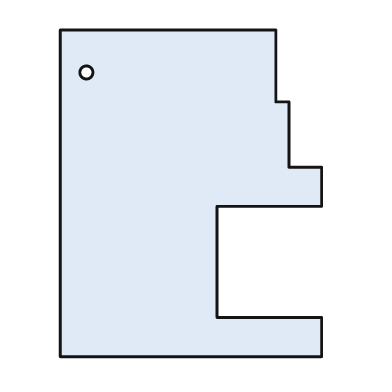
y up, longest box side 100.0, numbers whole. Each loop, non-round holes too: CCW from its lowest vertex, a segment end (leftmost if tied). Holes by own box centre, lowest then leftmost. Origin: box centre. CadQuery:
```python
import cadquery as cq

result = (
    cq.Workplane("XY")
    .moveTo(-40.0, -50.0)
    .lineTo(40.0, -50.0)
    .lineTo(40.0, -38.0)
    .lineTo(8.0, -38.0)
    .lineTo(8.0, -4.0)
    .lineTo(40.0, -4.0)
    .lineTo(40.0, 8.0)
    .lineTo(30.0, 8.0)
    .lineTo(30.0, 28.0)
    .lineTo(26.0, 28.0)
    .lineTo(26.0, 50.0)
    .lineTo(-40.0, 50.0)
    .close()
    .moveTo(-32.0, 37.0)
    .circle(2.0)
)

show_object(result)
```